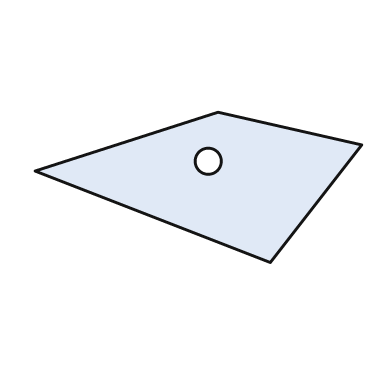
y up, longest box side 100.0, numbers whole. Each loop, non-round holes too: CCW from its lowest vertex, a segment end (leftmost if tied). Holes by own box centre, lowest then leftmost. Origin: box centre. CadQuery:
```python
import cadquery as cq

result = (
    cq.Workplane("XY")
    .moveTo(22.0, -23.0)
    .lineTo(50.0, 13.0)
    .lineTo(6.0, 23.0)
    .lineTo(-50.0, 5.0)
    .close()
    .moveTo(3.0, 8.0)
    .circle(4.0)
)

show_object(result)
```